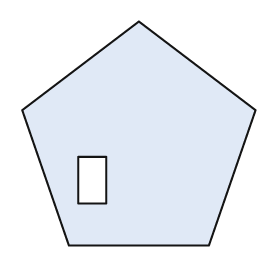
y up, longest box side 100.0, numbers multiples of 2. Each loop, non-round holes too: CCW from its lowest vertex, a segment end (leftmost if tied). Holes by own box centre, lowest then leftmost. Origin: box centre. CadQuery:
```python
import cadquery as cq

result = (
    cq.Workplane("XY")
    .moveTo(-30.0, -48.0)
    .lineTo(30.0, -48.0)
    .lineTo(50.0, 10.0)
    .lineTo(0.0, 48.0)
    .lineTo(-50.0, 10.0)
    .close()
    .moveTo(-26.0, -30.0)
    .lineTo(-14.0, -30.0)
    .lineTo(-14.0, -10.0)
    .lineTo(-26.0, -10.0)
    .close()
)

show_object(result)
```